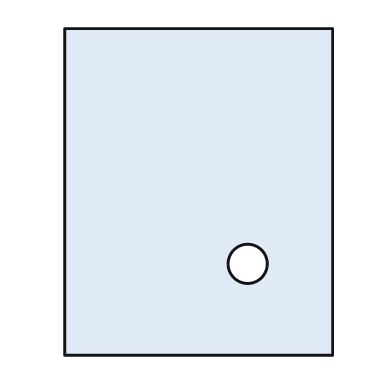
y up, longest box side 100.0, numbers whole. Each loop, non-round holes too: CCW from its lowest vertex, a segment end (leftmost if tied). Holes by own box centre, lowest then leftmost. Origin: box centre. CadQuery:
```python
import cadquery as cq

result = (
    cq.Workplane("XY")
    .moveTo(-41.0, -50.0)
    .lineTo(41.0, -50.0)
    .lineTo(41.0, 50.0)
    .lineTo(-41.0, 50.0)
    .close()
    .moveTo(15.0, -22.0)
    .circle(6.0)
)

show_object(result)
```